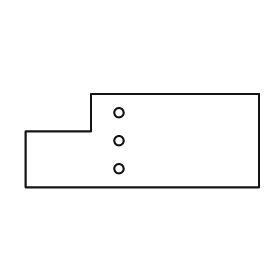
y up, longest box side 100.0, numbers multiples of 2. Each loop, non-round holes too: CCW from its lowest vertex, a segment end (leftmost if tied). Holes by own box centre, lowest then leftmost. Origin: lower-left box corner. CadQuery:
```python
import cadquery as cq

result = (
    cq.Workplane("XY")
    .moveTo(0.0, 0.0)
    .lineTo(100.0, 0.0)
    .lineTo(100.0, 40.0)
    .lineTo(28.0, 40.0)
    .lineTo(28.0, 24.0)
    .lineTo(0.0, 24.0)
    .close()
    .moveTo(40.0, 8.0)
    .circle(2.0)
    .moveTo(40.0, 20.0)
    .circle(2.0)
    .moveTo(40.0, 32.0)
    .circle(2.0)
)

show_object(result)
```